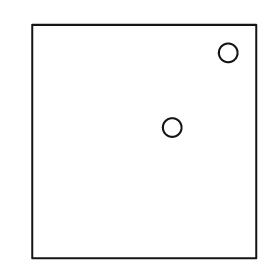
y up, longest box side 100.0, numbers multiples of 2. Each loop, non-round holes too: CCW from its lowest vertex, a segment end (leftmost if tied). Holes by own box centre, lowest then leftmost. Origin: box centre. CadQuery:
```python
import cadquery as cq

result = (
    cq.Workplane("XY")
    .moveTo(-48.0, -50.0)
    .lineTo(48.0, -50.0)
    .lineTo(48.0, 50.0)
    .lineTo(-48.0, 50.0)
    .close()
    .moveTo(12.0, 6.0)
    .circle(4.0)
    .moveTo(36.0, 38.0)
    .circle(4.0)
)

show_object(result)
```